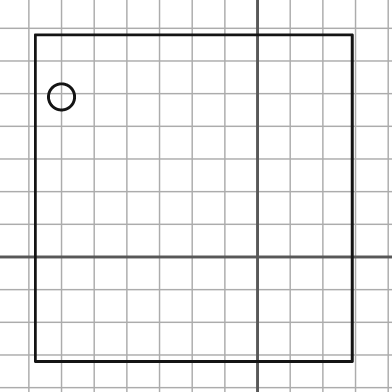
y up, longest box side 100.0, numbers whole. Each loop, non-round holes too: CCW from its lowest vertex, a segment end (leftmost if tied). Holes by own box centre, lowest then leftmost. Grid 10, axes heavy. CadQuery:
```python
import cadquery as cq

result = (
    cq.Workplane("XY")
    .moveTo(-68.0, -32.0)
    .lineTo(29.0, -32.0)
    .lineTo(29.0, 68.0)
    .lineTo(-68.0, 68.0)
    .close()
    .moveTo(-60.0, 49.0)
    .circle(4.0)
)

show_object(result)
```